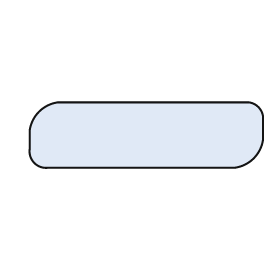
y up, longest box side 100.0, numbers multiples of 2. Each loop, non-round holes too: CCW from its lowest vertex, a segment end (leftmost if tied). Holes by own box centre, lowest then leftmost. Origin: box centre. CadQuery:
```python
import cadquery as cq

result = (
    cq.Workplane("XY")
    .moveTo(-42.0, -14.0)
    .lineTo(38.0, -14.0)
    .threePointArc((46.0, -10.0), (50.0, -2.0))
    .lineTo(50.0, 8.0)
    .threePointArc((48.0, 12.0), (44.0, 14.0))
    .lineTo(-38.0, 14.0)
    .threePointArc((-46.0, 10.0), (-50.0, 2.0))
    .lineTo(-50.0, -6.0)
    .threePointArc((-48.0, -12.0), (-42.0, -14.0))
    .close()
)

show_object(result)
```